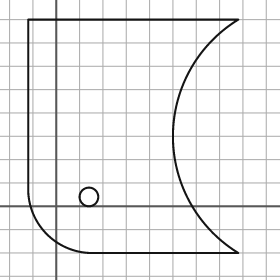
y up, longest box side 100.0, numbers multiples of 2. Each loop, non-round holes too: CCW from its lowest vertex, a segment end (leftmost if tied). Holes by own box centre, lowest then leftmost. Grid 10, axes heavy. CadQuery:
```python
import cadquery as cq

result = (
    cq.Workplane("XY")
    .moveTo(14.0, -20.0)
    .lineTo(78.0, -20.0)
    .threePointArc((50.0, 30.0), (78.0, 80.0))
    .lineTo(-12.0, 80.0)
    .lineTo(-12.0, 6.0)
    .threePointArc((-4.0, -12.0), (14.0, -20.0))
    .close()
    .moveTo(14.0, 4.0)
    .circle(4.0)
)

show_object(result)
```